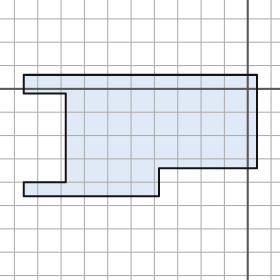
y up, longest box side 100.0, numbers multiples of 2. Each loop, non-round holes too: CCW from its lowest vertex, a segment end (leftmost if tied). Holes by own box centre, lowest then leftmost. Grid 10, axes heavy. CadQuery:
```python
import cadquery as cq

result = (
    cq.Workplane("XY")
    .moveTo(-96.0, -46.0)
    .lineTo(-38.0, -46.0)
    .lineTo(-38.0, -34.0)
    .lineTo(4.0, -34.0)
    .lineTo(4.0, 6.0)
    .lineTo(-96.0, 6.0)
    .lineTo(-96.0, -2.0)
    .lineTo(-78.0, -2.0)
    .lineTo(-78.0, -40.0)
    .lineTo(-96.0, -40.0)
    .close()
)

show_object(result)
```